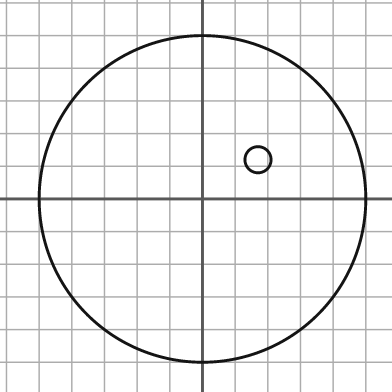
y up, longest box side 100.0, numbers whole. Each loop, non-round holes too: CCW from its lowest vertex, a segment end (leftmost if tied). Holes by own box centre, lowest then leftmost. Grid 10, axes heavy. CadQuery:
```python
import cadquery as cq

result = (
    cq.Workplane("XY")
    .moveTo(0.0, 0.0)
    .circle(50.0)
    .moveTo(17.0, 12.0)
    .circle(4.0)
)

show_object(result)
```